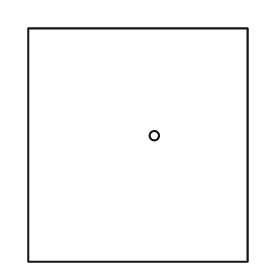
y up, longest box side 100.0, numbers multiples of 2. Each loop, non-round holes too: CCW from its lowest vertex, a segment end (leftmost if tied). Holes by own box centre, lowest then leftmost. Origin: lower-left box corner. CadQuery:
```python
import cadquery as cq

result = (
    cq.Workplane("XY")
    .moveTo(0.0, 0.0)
    .lineTo(94.0, 0.0)
    .lineTo(94.0, 100.0)
    .lineTo(0.0, 100.0)
    .close()
    .moveTo(54.0, 54.0)
    .circle(2.0)
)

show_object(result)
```